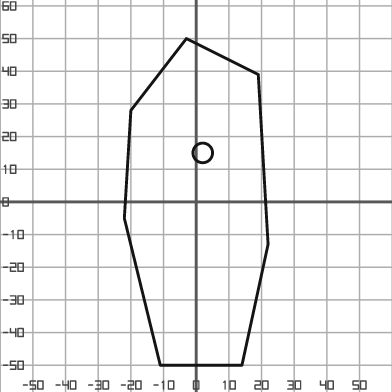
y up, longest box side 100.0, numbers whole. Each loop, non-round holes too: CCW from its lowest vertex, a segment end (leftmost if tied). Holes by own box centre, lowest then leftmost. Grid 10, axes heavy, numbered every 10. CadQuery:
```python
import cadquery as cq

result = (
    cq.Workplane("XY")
    .moveTo(-11.0, -50.0)
    .lineTo(14.0, -50.0)
    .lineTo(22.0, -13.0)
    .lineTo(19.0, 39.0)
    .lineTo(-3.0, 50.0)
    .lineTo(-20.0, 28.0)
    .lineTo(-22.0, -5.0)
    .close()
    .moveTo(2.0, 15.0)
    .circle(3.0)
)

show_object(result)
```